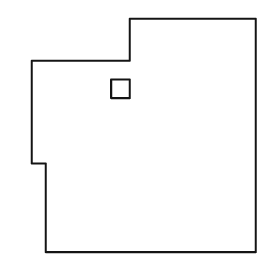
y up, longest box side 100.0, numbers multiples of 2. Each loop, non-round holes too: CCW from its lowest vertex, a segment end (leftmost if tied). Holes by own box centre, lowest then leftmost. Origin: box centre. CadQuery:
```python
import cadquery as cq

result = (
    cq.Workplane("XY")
    .moveTo(-42.0, -50.0)
    .lineTo(48.0, -50.0)
    .lineTo(48.0, 50.0)
    .lineTo(-6.0, 50.0)
    .lineTo(-6.0, 32.0)
    .lineTo(-48.0, 32.0)
    .lineTo(-48.0, -12.0)
    .lineTo(-42.0, -12.0)
    .close()
    .moveTo(-14.0, 16.0)
    .lineTo(-6.0, 16.0)
    .lineTo(-6.0, 24.0)
    .lineTo(-14.0, 24.0)
    .close()
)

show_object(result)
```